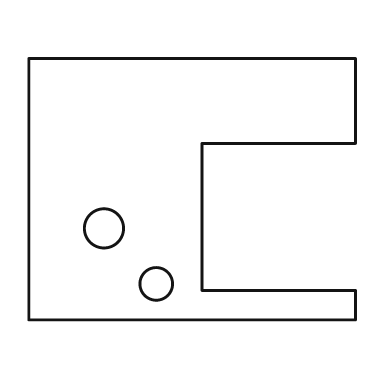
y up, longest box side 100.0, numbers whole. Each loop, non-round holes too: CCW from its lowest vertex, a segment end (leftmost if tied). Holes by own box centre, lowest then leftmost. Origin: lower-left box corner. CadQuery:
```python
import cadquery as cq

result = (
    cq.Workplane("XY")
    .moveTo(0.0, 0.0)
    .lineTo(100.0, 0.0)
    .lineTo(100.0, 9.0)
    .lineTo(53.0, 9.0)
    .lineTo(53.0, 54.0)
    .lineTo(100.0, 54.0)
    .lineTo(100.0, 80.0)
    .lineTo(0.0, 80.0)
    .close()
    .moveTo(39.0, 11.0)
    .circle(5.0)
    .moveTo(23.0, 28.0)
    .circle(6.0)
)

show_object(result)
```